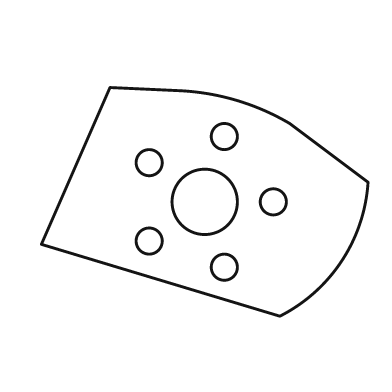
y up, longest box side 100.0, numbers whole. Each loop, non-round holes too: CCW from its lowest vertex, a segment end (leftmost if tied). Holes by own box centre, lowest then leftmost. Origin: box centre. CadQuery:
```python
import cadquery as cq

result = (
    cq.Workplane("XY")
    .moveTo(23.0, -35.0)
    .threePointArc((42.0, -18.0), (50.0, 6.0))
    .lineTo(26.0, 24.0)
    .threePointArc((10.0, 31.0), (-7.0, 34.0))
    .lineTo(-29.0, 35.0)
    .lineTo(-50.0, -13.0)
    .close()
    .moveTo(6.0, -20.0)
    .circle(4.0)
    .moveTo(-17.0, -12.0)
    .circle(4.0)
    .moveTo(0.0, 0.0)
    .circle(10.0)
    .moveTo(21.0, 0.0)
    .circle(4.0)
    .moveTo(-17.0, 12.0)
    .circle(4.0)
    .moveTo(6.0, 20.0)
    .circle(4.0)
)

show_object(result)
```